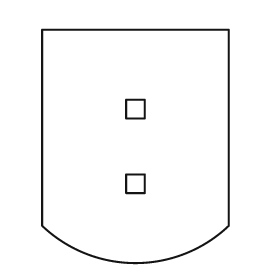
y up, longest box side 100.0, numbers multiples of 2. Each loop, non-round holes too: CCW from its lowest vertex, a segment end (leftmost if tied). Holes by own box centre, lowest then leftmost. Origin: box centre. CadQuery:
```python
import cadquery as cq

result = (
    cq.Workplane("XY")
    .moveTo(-40.0, -34.0)
    .threePointArc((0.0, -50.0), (40.0, -34.0))
    .lineTo(40.0, 50.0)
    .lineTo(-40.0, 50.0)
    .close()
    .moveTo(-4.0, -20.0)
    .lineTo(4.0, -20.0)
    .lineTo(4.0, -12.0)
    .lineTo(-4.0, -12.0)
    .close()
    .moveTo(-4.0, 12.0)
    .lineTo(4.0, 12.0)
    .lineTo(4.0, 20.0)
    .lineTo(-4.0, 20.0)
    .close()
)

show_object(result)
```